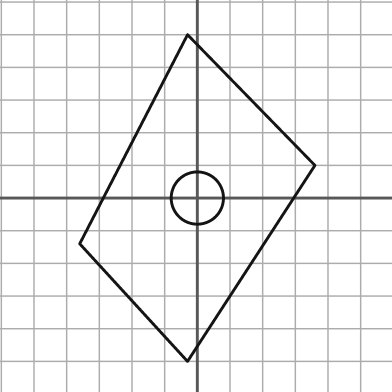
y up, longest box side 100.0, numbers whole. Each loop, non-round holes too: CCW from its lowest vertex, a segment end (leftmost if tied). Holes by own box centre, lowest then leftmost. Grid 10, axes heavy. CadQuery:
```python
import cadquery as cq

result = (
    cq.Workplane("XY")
    .moveTo(-3.0, -50.0)
    .lineTo(36.0, 10.0)
    .lineTo(-3.0, 50.0)
    .lineTo(-36.0, -14.0)
    .close()
    .moveTo(0.0, 0.0)
    .circle(8.0)
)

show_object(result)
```